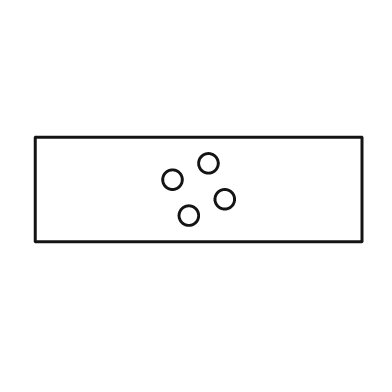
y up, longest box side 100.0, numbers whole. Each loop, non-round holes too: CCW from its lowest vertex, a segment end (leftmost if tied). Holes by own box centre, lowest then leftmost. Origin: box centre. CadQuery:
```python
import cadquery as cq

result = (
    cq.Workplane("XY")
    .moveTo(-50.0, -16.0)
    .lineTo(50.0, -16.0)
    .lineTo(50.0, 16.0)
    .lineTo(-50.0, 16.0)
    .close()
    .moveTo(-3.0, -8.0)
    .circle(3.0)
    .moveTo(8.0, -3.0)
    .circle(3.0)
    .moveTo(-8.0, 3.0)
    .circle(3.0)
    .moveTo(3.0, 8.0)
    .circle(3.0)
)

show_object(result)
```